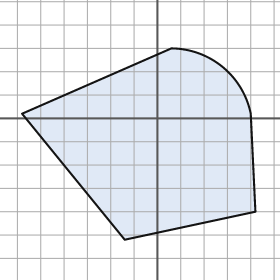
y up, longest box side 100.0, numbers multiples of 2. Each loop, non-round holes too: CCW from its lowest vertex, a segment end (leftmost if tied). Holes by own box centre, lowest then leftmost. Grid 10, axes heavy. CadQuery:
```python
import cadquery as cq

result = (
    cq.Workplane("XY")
    .moveTo(-14.0, -52.0)
    .lineTo(42.0, -40.0)
    .lineTo(40.0, 2.0)
    .threePointArc((28.0, 22.0), (6.0, 30.0))
    .lineTo(-58.0, 2.0)
    .close()
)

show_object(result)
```